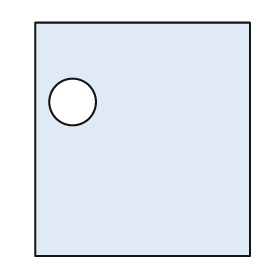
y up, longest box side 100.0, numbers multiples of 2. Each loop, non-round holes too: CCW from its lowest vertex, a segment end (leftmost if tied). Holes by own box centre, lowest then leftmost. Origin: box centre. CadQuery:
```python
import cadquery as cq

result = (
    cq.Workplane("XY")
    .moveTo(-46.0, -50.0)
    .lineTo(46.0, -50.0)
    .lineTo(46.0, 50.0)
    .lineTo(-46.0, 50.0)
    .close()
    .moveTo(-30.0, 16.0)
    .circle(10.0)
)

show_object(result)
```